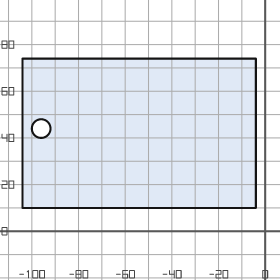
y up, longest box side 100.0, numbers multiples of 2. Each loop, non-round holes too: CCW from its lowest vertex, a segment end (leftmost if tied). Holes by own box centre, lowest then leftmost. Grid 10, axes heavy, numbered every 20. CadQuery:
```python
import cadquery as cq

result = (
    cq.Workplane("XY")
    .moveTo(-104.0, 10.0)
    .lineTo(-4.0, 10.0)
    .lineTo(-4.0, 74.0)
    .lineTo(-104.0, 74.0)
    .close()
    .moveTo(-96.0, 44.0)
    .circle(4.0)
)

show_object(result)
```